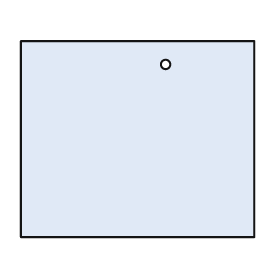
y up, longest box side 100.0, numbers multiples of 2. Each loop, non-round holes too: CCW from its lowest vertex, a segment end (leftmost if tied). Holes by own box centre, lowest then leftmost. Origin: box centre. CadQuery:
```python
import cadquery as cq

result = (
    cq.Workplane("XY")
    .moveTo(-50.0, -42.0)
    .lineTo(50.0, -42.0)
    .lineTo(50.0, 42.0)
    .lineTo(-50.0, 42.0)
    .close()
    .moveTo(12.0, 32.0)
    .circle(2.0)
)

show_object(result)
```